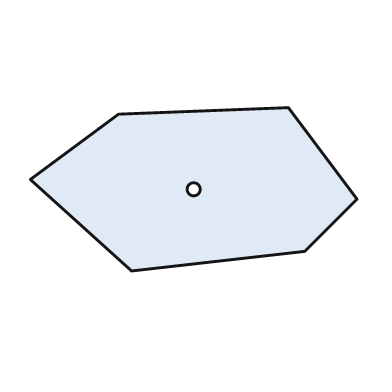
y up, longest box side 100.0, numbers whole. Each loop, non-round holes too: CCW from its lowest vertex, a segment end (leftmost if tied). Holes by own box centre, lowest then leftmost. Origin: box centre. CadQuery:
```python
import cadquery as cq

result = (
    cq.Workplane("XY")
    .moveTo(-19.0, -25.0)
    .lineTo(34.0, -19.0)
    .lineTo(50.0, -3.0)
    .lineTo(29.0, 25.0)
    .lineTo(-23.0, 23.0)
    .lineTo(-50.0, 3.0)
    .close()
    .moveTo(0.0, 0.0)
    .circle(2.0)
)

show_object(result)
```